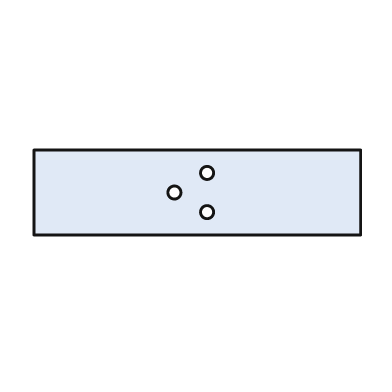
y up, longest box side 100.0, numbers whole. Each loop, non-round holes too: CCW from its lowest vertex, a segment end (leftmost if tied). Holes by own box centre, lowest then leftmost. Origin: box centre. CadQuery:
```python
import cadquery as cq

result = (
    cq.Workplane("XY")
    .moveTo(-50.0, -13.0)
    .lineTo(50.0, -13.0)
    .lineTo(50.0, 13.0)
    .lineTo(-50.0, 13.0)
    .close()
    .moveTo(3.0, -6.0)
    .circle(2.0)
    .moveTo(-7.0, 0.0)
    .circle(2.0)
    .moveTo(3.0, 6.0)
    .circle(2.0)
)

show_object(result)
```